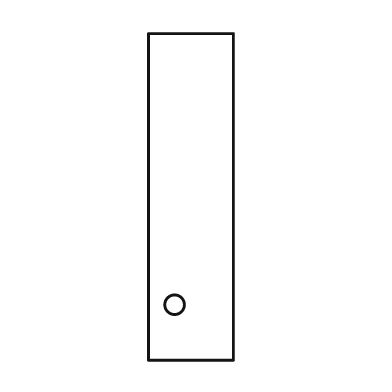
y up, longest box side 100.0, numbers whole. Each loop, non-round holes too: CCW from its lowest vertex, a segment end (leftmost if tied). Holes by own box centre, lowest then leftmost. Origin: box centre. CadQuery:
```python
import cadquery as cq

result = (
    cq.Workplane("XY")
    .moveTo(-13.0, -50.0)
    .lineTo(13.0, -50.0)
    .lineTo(13.0, 50.0)
    .lineTo(-13.0, 50.0)
    .close()
    .moveTo(-5.0, -33.0)
    .circle(3.0)
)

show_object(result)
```